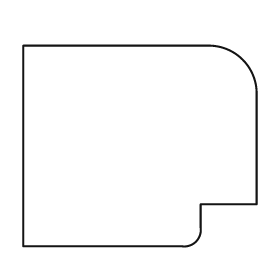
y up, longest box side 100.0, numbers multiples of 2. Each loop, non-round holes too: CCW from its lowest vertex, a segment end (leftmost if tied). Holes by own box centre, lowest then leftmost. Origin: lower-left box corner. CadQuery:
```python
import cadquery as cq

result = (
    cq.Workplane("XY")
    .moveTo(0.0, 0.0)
    .lineTo(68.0, 0.0)
    .threePointArc((74.0, 2.0), (76.0, 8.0))
    .lineTo(76.0, 18.0)
    .lineTo(100.0, 18.0)
    .lineTo(100.0, 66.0)
    .threePointArc((94.0, 80.0), (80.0, 86.0))
    .lineTo(0.0, 86.0)
    .close()
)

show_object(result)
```